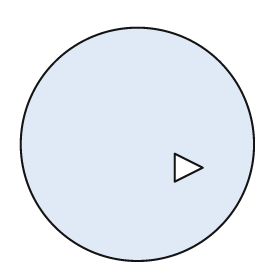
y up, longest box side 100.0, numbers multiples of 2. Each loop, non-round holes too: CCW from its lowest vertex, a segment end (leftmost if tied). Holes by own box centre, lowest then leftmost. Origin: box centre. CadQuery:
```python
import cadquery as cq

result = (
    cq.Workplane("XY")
    .moveTo(0.0, 0.0)
    .circle(50.0)
    .moveTo(16.0, -16.0)
    .lineTo(28.0, -10.0)
    .lineTo(16.0, -4.0)
    .close()
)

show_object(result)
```